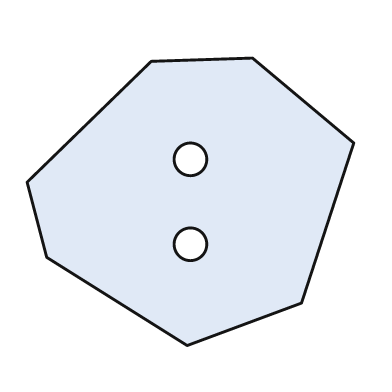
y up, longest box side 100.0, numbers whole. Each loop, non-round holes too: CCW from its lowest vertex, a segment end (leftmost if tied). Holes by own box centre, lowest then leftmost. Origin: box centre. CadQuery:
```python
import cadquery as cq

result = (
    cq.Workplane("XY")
    .moveTo(-1.0, -44.0)
    .lineTo(34.0, -31.0)
    .lineTo(50.0, 18.0)
    .lineTo(19.0, 44.0)
    .lineTo(-12.0, 43.0)
    .lineTo(-50.0, 6.0)
    .lineTo(-44.0, -17.0)
    .close()
    .moveTo(0.0, -13.0)
    .circle(5.0)
    .moveTo(0.0, 13.0)
    .circle(5.0)
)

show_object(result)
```